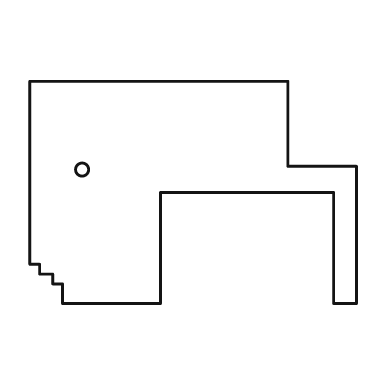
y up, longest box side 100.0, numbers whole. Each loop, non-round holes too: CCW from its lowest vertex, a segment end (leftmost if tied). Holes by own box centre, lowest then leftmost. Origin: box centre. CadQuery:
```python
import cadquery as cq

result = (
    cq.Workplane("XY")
    .moveTo(-40.0, -34.0)
    .lineTo(-10.0, -34.0)
    .lineTo(-10.0, 0.0)
    .lineTo(43.0, 0.0)
    .lineTo(43.0, -34.0)
    .lineTo(50.0, -34.0)
    .lineTo(50.0, 8.0)
    .lineTo(29.0, 8.0)
    .lineTo(29.0, 34.0)
    .lineTo(-50.0, 34.0)
    .lineTo(-50.0, -22.0)
    .lineTo(-47.0, -22.0)
    .lineTo(-47.0, -25.0)
    .lineTo(-43.0, -25.0)
    .lineTo(-43.0, -28.0)
    .lineTo(-40.0, -28.0)
    .close()
    .moveTo(-34.0, 7.0)
    .circle(2.0)
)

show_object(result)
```